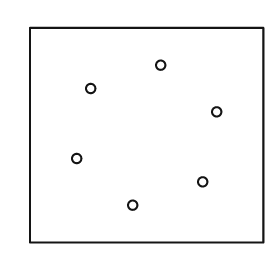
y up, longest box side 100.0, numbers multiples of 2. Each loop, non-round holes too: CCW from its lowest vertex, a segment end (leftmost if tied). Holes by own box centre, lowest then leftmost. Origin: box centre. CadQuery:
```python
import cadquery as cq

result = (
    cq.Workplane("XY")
    .moveTo(-50.0, -46.0)
    .lineTo(50.0, -46.0)
    .lineTo(50.0, 46.0)
    .lineTo(-50.0, 46.0)
    .close()
    .moveTo(-6.0, -30.0)
    .circle(2.0)
    .moveTo(24.0, -20.0)
    .circle(2.0)
    .moveTo(-30.0, -10.0)
    .circle(2.0)
    .moveTo(30.0, 10.0)
    .circle(2.0)
    .moveTo(-24.0, 20.0)
    .circle(2.0)
    .moveTo(6.0, 30.0)
    .circle(2.0)
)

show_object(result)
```